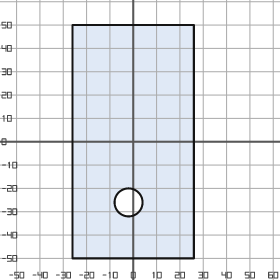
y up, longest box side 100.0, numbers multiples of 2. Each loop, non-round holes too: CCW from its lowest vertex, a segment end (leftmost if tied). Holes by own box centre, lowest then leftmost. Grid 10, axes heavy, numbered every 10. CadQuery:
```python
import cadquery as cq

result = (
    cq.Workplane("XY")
    .moveTo(-26.0, -50.0)
    .lineTo(26.0, -50.0)
    .lineTo(26.0, 50.0)
    .lineTo(-26.0, 50.0)
    .close()
    .moveTo(-2.0, -26.0)
    .circle(6.0)
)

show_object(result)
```